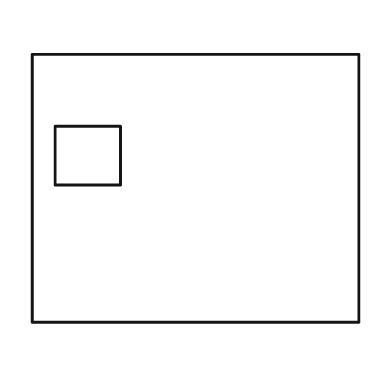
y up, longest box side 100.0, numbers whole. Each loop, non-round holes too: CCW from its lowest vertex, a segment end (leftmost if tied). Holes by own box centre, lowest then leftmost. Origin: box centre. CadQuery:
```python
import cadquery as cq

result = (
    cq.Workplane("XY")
    .moveTo(-50.0, -41.0)
    .lineTo(50.0, -41.0)
    .lineTo(50.0, 41.0)
    .lineTo(-50.0, 41.0)
    .close()
    .moveTo(-43.0, 1.0)
    .lineTo(-23.0, 1.0)
    .lineTo(-23.0, 19.0)
    .lineTo(-43.0, 19.0)
    .close()
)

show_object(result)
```